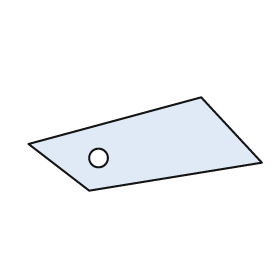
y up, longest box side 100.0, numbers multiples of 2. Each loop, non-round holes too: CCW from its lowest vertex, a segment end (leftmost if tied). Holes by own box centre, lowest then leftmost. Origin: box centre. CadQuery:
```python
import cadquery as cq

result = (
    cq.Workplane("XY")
    .moveTo(-24.0, -20.0)
    .lineTo(50.0, -8.0)
    .lineTo(24.0, 20.0)
    .lineTo(-50.0, 0.0)
    .close()
    .moveTo(-20.0, -6.0)
    .circle(4.0)
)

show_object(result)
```